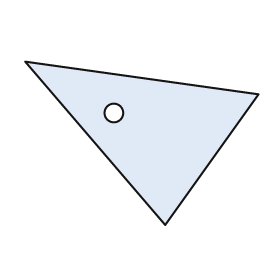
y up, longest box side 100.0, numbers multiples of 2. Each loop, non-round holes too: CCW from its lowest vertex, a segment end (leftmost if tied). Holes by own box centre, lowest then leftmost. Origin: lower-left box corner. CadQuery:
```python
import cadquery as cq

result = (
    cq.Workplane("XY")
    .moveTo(60.0, 0.0)
    .lineTo(100.0, 56.0)
    .lineTo(0.0, 70.0)
    .close()
    .moveTo(38.0, 48.0)
    .circle(4.0)
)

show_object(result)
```